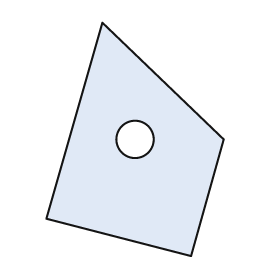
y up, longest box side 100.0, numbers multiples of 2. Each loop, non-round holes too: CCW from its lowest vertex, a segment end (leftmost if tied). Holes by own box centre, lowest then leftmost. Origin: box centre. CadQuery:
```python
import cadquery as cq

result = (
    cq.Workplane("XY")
    .moveTo(24.0, -50.0)
    .lineTo(38.0, 0.0)
    .lineTo(-14.0, 50.0)
    .lineTo(-38.0, -34.0)
    .close()
    .moveTo(0.0, 0.0)
    .circle(8.0)
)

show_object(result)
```